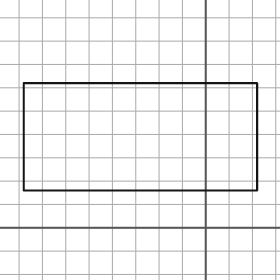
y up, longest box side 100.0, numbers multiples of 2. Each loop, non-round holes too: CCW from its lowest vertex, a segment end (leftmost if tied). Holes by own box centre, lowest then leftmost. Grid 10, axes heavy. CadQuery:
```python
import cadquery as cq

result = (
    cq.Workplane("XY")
    .moveTo(-78.0, 16.0)
    .lineTo(22.0, 16.0)
    .lineTo(22.0, 62.0)
    .lineTo(-78.0, 62.0)
    .close()
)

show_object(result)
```